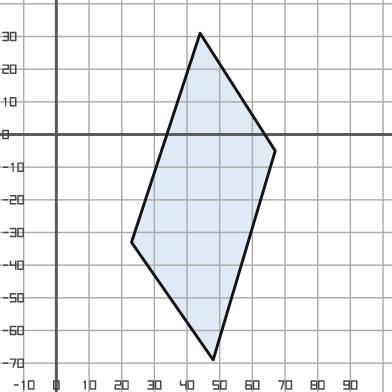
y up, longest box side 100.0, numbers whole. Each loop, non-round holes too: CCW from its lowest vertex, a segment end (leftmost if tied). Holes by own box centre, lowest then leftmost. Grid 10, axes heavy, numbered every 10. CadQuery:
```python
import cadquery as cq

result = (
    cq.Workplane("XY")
    .moveTo(48.0, -69.0)
    .lineTo(67.0, -5.0)
    .lineTo(44.0, 31.0)
    .lineTo(23.0, -33.0)
    .close()
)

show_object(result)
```